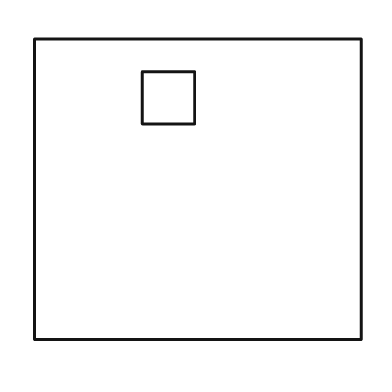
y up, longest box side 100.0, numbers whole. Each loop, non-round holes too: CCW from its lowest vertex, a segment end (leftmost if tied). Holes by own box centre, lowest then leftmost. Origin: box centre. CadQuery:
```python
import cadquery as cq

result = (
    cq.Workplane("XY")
    .moveTo(-50.0, -46.0)
    .lineTo(50.0, -46.0)
    .lineTo(50.0, 46.0)
    .lineTo(-50.0, 46.0)
    .close()
    .moveTo(-17.0, 20.0)
    .lineTo(-1.0, 20.0)
    .lineTo(-1.0, 36.0)
    .lineTo(-17.0, 36.0)
    .close()
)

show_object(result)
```